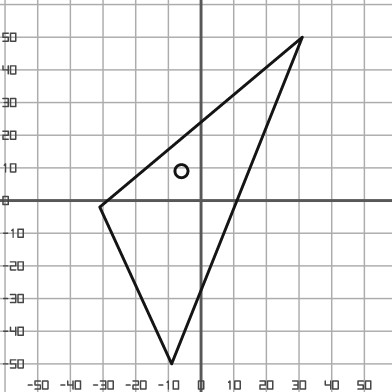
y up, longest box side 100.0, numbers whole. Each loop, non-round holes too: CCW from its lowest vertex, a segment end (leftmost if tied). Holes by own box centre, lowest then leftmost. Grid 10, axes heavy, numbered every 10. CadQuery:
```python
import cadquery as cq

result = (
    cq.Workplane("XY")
    .moveTo(-9.0, -50.0)
    .lineTo(31.0, 50.0)
    .lineTo(-31.0, -2.0)
    .close()
    .moveTo(-6.0, 9.0)
    .circle(2.0)
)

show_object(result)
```